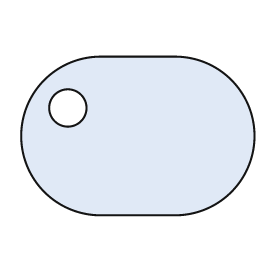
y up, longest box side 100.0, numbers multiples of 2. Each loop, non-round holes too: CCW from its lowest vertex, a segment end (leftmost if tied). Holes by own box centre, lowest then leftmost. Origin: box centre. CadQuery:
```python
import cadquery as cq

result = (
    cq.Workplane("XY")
    .moveTo(-16.0, -34.0)
    .lineTo(16.0, -34.0)
    .threePointArc((50.0, 0.0), (16.0, 34.0))
    .lineTo(-16.0, 34.0)
    .threePointArc((-50.0, 0.0), (-16.0, -34.0))
    .close()
    .moveTo(-30.0, 12.0)
    .circle(8.0)
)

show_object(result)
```